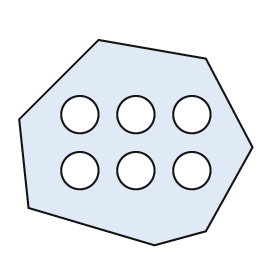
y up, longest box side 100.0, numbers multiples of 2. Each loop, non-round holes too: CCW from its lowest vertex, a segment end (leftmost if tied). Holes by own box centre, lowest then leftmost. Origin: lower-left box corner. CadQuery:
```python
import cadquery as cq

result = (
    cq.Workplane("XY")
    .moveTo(58.0, 0.0)
    .lineTo(80.0, 6.0)
    .lineTo(100.0, 42.0)
    .lineTo(80.0, 80.0)
    .lineTo(34.0, 88.0)
    .lineTo(0.0, 54.0)
    .lineTo(4.0, 16.0)
    .close()
    .moveTo(26.0, 32.0)
    .circle(8.0)
    .moveTo(50.0, 32.0)
    .circle(8.0)
    .moveTo(74.0, 32.0)
    .circle(8.0)
    .moveTo(26.0, 56.0)
    .circle(8.0)
    .moveTo(50.0, 56.0)
    .circle(8.0)
    .moveTo(74.0, 56.0)
    .circle(8.0)
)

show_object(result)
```